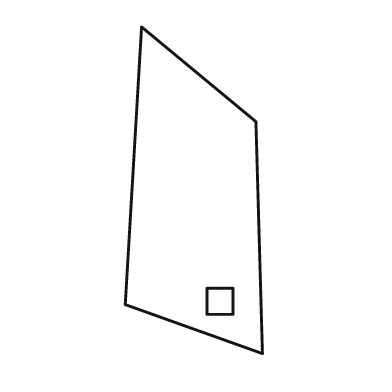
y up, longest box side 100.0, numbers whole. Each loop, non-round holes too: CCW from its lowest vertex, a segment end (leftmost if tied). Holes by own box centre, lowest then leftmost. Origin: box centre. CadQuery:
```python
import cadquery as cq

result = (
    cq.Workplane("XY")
    .moveTo(21.0, -50.0)
    .lineTo(19.0, 21.0)
    .lineTo(-16.0, 50.0)
    .lineTo(-21.0, -35.0)
    .close()
    .moveTo(4.0, -38.0)
    .lineTo(12.0, -38.0)
    .lineTo(12.0, -30.0)
    .lineTo(4.0, -30.0)
    .close()
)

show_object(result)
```